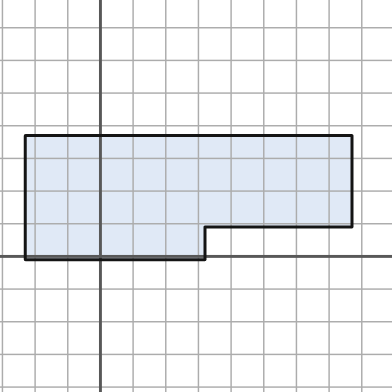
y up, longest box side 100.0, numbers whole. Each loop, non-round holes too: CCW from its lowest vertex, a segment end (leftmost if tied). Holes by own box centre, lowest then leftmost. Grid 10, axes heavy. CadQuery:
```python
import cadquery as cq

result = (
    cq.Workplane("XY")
    .moveTo(-23.0, -1.0)
    .lineTo(32.0, -1.0)
    .lineTo(32.0, 9.0)
    .lineTo(77.0, 9.0)
    .lineTo(77.0, 37.0)
    .lineTo(-23.0, 37.0)
    .close()
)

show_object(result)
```